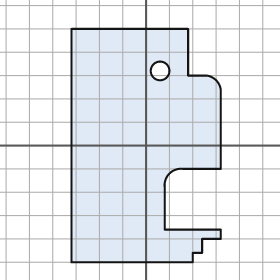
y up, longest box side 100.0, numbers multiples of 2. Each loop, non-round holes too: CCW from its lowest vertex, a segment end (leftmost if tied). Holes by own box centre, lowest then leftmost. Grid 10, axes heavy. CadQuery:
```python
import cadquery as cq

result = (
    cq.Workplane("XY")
    .moveTo(-32.0, -50.0)
    .lineTo(20.0, -50.0)
    .lineTo(20.0, -46.0)
    .lineTo(24.0, -46.0)
    .lineTo(24.0, -40.0)
    .lineTo(32.0, -40.0)
    .lineTo(32.0, -36.0)
    .lineTo(8.0, -36.0)
    .lineTo(8.0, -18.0)
    .threePointArc((10.0, -12.0), (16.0, -10.0))
    .lineTo(32.0, -10.0)
    .lineTo(32.0, 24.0)
    .threePointArc((30.0, 28.0), (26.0, 30.0))
    .lineTo(18.0, 30.0)
    .lineTo(18.0, 50.0)
    .lineTo(-32.0, 50.0)
    .close()
    .moveTo(6.0, 32.0)
    .circle(4.0)
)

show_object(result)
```